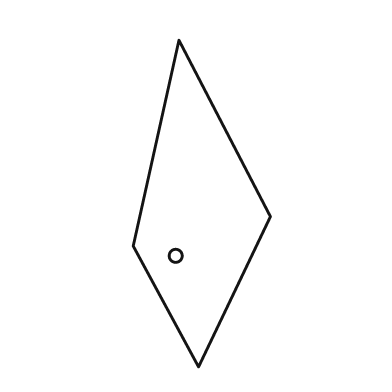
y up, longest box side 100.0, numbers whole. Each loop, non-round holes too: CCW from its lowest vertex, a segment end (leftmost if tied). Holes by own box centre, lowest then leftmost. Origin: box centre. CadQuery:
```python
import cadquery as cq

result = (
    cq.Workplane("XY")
    .moveTo(-1.0, -50.0)
    .lineTo(21.0, -4.0)
    .lineTo(-7.0, 50.0)
    .lineTo(-21.0, -13.0)
    .close()
    .moveTo(-8.0, -16.0)
    .circle(2.0)
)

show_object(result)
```